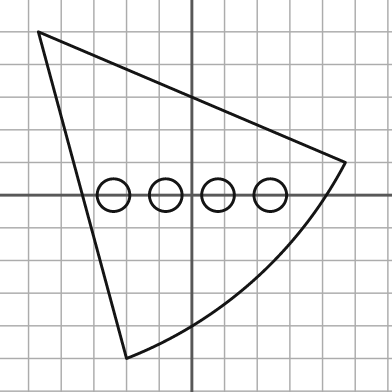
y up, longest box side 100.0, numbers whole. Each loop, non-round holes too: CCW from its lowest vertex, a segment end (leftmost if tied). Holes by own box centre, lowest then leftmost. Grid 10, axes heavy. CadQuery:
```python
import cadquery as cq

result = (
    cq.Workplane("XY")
    .moveTo(-20.0, -50.0)
    .threePointArc((19.0, -26.0), (47.0, 10.0))
    .lineTo(-47.0, 50.0)
    .close()
    .moveTo(-24.0, 0.0)
    .circle(5.0)
    .moveTo(-8.0, 0.0)
    .circle(5.0)
    .moveTo(8.0, 0.0)
    .circle(5.0)
    .moveTo(24.0, 0.0)
    .circle(5.0)
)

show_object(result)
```